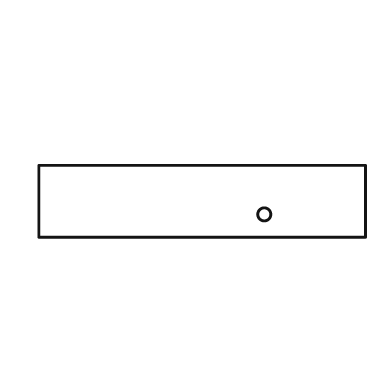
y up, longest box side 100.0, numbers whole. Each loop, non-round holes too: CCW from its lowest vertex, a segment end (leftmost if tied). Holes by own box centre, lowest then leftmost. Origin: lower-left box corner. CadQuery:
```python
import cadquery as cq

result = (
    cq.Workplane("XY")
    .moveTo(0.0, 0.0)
    .lineTo(100.0, 0.0)
    .lineTo(100.0, 22.0)
    .lineTo(0.0, 22.0)
    .close()
    .moveTo(69.0, 7.0)
    .circle(2.0)
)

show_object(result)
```